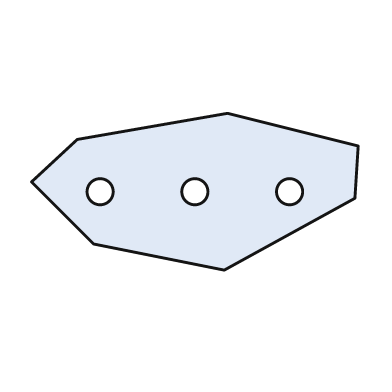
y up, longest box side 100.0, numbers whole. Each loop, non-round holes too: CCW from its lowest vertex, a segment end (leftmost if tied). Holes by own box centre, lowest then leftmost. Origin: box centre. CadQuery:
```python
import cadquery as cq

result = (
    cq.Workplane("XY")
    .moveTo(9.0, -24.0)
    .lineTo(49.0, -2.0)
    .lineTo(50.0, 14.0)
    .lineTo(10.0, 24.0)
    .lineTo(-36.0, 16.0)
    .lineTo(-50.0, 3.0)
    .lineTo(-31.0, -16.0)
    .close()
    .moveTo(-29.0, 0.0)
    .circle(4.0)
    .moveTo(0.0, 0.0)
    .circle(4.0)
    .moveTo(29.0, 0.0)
    .circle(4.0)
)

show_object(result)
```